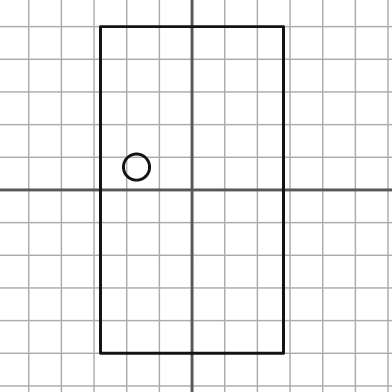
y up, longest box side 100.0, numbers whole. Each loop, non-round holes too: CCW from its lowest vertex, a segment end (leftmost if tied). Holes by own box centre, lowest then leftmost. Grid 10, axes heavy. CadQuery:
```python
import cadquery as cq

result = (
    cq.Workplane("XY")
    .moveTo(-28.0, -50.0)
    .lineTo(28.0, -50.0)
    .lineTo(28.0, 50.0)
    .lineTo(-28.0, 50.0)
    .close()
    .moveTo(-17.0, 7.0)
    .circle(4.0)
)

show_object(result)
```